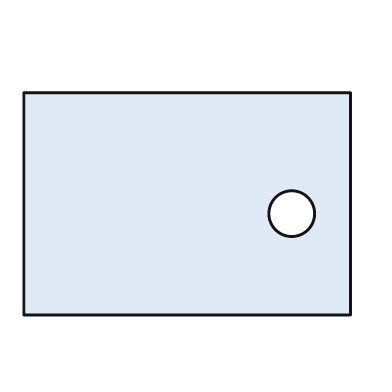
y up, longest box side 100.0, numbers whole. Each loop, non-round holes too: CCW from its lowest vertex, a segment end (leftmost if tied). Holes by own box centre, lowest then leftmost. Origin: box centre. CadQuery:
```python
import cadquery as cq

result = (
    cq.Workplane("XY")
    .moveTo(-50.0, -34.0)
    .lineTo(50.0, -34.0)
    .lineTo(50.0, 34.0)
    .lineTo(-50.0, 34.0)
    .close()
    .moveTo(32.0, -3.0)
    .circle(7.0)
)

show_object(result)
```